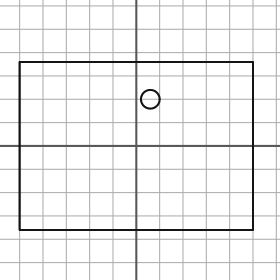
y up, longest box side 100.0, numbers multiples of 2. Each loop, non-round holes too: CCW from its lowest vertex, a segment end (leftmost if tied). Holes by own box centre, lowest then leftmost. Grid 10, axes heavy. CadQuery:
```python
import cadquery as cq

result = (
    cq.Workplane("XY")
    .moveTo(-50.0, -36.0)
    .lineTo(50.0, -36.0)
    .lineTo(50.0, 36.0)
    .lineTo(-50.0, 36.0)
    .close()
    .moveTo(6.0, 20.0)
    .circle(4.0)
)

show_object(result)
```